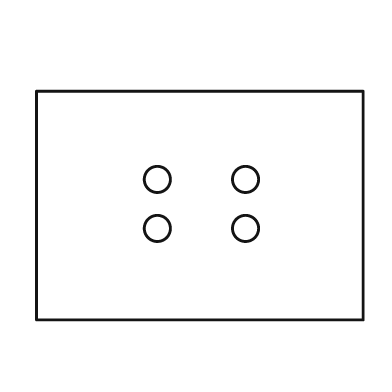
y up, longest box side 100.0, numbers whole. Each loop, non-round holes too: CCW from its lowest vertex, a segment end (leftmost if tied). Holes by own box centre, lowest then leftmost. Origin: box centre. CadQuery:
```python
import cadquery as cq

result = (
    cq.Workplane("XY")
    .moveTo(-50.0, -35.0)
    .lineTo(50.0, -35.0)
    .lineTo(50.0, 35.0)
    .lineTo(-50.0, 35.0)
    .close()
    .moveTo(-13.0, -7.0)
    .circle(4.0)
    .moveTo(14.0, -7.0)
    .circle(4.0)
    .moveTo(-13.0, 8.0)
    .circle(4.0)
    .moveTo(14.0, 8.0)
    .circle(4.0)
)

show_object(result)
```